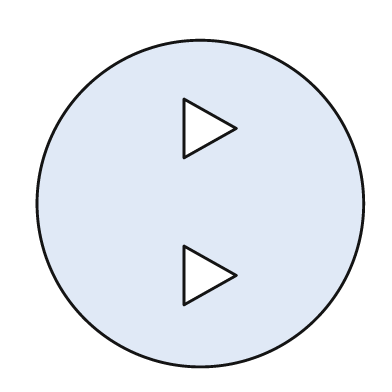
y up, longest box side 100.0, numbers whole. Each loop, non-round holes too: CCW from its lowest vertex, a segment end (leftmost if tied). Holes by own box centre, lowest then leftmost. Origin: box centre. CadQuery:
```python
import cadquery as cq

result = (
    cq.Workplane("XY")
    .moveTo(0.0, 0.0)
    .circle(50.0)
    .moveTo(-5.0, -31.0)
    .lineTo(11.0, -22.0)
    .lineTo(-5.0, -13.0)
    .close()
    .moveTo(-5.0, 14.0)
    .lineTo(11.0, 23.0)
    .lineTo(-5.0, 32.0)
    .close()
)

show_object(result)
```